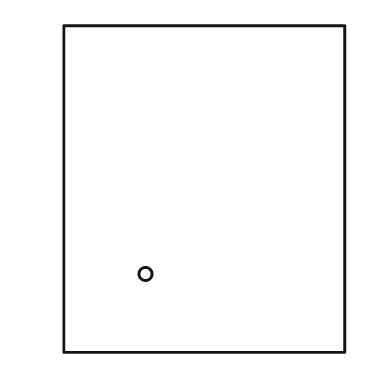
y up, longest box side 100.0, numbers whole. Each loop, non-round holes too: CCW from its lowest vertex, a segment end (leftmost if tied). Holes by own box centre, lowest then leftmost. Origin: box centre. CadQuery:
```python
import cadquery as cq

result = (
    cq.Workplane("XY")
    .moveTo(-43.0, -50.0)
    .lineTo(43.0, -50.0)
    .lineTo(43.0, 50.0)
    .lineTo(-43.0, 50.0)
    .close()
    .moveTo(-18.0, -26.0)
    .circle(2.0)
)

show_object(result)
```